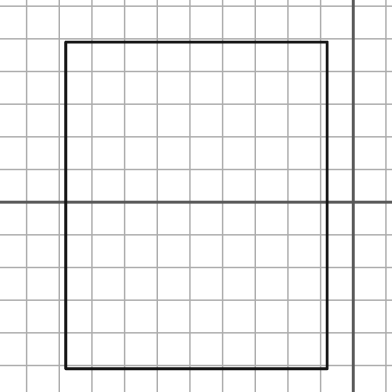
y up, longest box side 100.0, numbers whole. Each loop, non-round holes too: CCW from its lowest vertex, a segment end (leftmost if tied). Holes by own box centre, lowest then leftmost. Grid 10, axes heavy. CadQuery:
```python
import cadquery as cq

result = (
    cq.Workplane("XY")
    .moveTo(-88.0, -51.0)
    .lineTo(-8.0, -51.0)
    .lineTo(-8.0, 49.0)
    .lineTo(-88.0, 49.0)
    .close()
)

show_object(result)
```